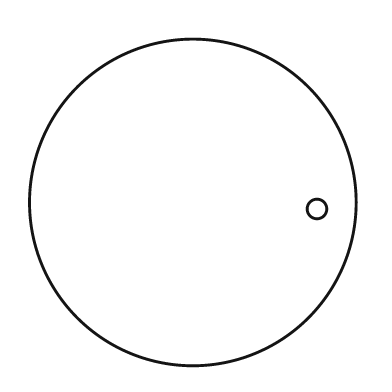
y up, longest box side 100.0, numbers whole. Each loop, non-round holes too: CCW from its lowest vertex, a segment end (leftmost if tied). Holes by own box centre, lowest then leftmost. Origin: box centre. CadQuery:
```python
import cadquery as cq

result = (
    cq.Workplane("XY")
    .moveTo(0.0, 0.0)
    .circle(50.0)
    .moveTo(38.0, -2.0)
    .circle(3.0)
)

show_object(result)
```